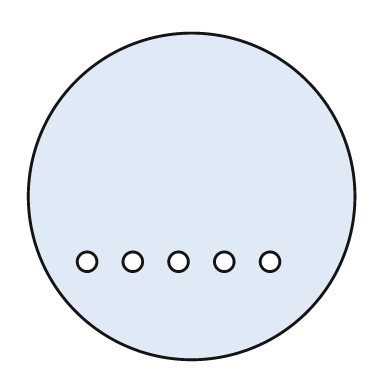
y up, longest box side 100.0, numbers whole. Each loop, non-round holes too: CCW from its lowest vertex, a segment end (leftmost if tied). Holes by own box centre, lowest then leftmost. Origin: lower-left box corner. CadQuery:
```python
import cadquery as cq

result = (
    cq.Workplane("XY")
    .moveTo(50.0, 50.0)
    .circle(50.0)
    .moveTo(18.0, 30.0)
    .circle(3.0)
    .moveTo(32.0, 30.0)
    .circle(3.0)
    .moveTo(46.0, 30.0)
    .circle(3.0)
    .moveTo(60.0, 30.0)
    .circle(3.0)
    .moveTo(74.0, 30.0)
    .circle(3.0)
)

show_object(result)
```